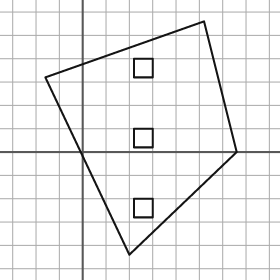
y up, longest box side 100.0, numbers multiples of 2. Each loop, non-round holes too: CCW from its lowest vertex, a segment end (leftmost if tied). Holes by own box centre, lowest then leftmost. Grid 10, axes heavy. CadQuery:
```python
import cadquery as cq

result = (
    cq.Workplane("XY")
    .moveTo(20.0, -44.0)
    .lineTo(66.0, 0.0)
    .lineTo(52.0, 56.0)
    .lineTo(-16.0, 32.0)
    .close()
    .moveTo(22.0, -28.0)
    .lineTo(30.0, -28.0)
    .lineTo(30.0, -20.0)
    .lineTo(22.0, -20.0)
    .close()
    .moveTo(22.0, 2.0)
    .lineTo(30.0, 2.0)
    .lineTo(30.0, 10.0)
    .lineTo(22.0, 10.0)
    .close()
    .moveTo(22.0, 32.0)
    .lineTo(30.0, 32.0)
    .lineTo(30.0, 40.0)
    .lineTo(22.0, 40.0)
    .close()
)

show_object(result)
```